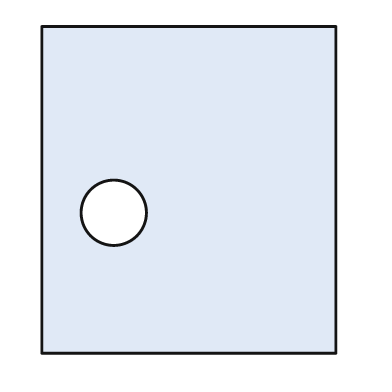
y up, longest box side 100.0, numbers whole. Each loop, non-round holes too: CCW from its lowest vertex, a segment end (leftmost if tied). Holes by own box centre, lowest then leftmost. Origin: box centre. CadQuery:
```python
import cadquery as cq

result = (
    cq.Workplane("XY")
    .moveTo(-45.0, -50.0)
    .lineTo(45.0, -50.0)
    .lineTo(45.0, 50.0)
    .lineTo(-45.0, 50.0)
    .close()
    .moveTo(-23.0, -7.0)
    .circle(10.0)
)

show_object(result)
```